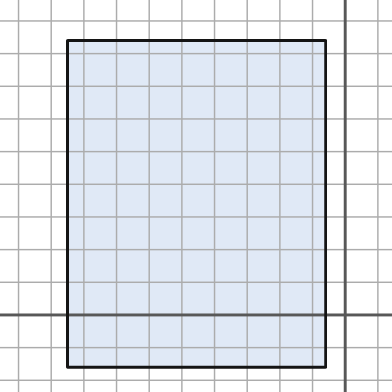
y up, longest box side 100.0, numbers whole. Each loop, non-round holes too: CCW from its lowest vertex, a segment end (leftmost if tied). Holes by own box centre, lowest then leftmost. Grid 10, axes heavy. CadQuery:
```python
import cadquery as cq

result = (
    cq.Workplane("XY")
    .moveTo(-85.0, -16.0)
    .lineTo(-6.0, -16.0)
    .lineTo(-6.0, 84.0)
    .lineTo(-85.0, 84.0)
    .close()
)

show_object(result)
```